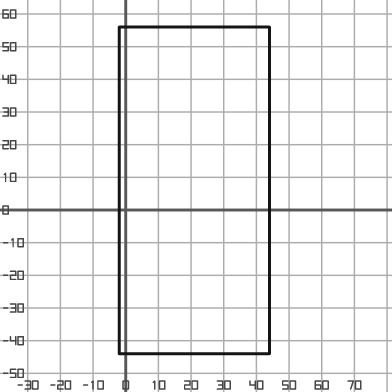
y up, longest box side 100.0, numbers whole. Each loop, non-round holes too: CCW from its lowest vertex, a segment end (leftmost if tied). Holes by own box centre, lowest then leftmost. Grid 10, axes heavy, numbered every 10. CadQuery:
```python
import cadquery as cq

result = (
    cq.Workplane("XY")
    .moveTo(-2.0, -44.0)
    .lineTo(44.0, -44.0)
    .lineTo(44.0, 56.0)
    .lineTo(-2.0, 56.0)
    .close()
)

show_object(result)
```